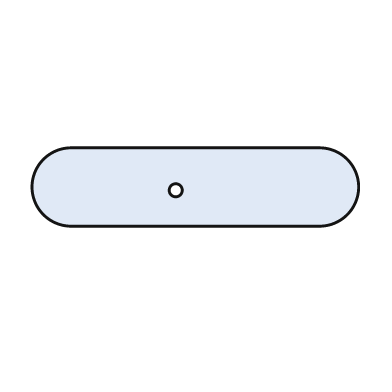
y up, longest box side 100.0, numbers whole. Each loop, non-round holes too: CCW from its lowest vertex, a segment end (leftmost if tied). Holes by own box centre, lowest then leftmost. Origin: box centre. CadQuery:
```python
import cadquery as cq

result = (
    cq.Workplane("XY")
    .moveTo(-38.0, -12.0)
    .lineTo(38.0, -12.0)
    .threePointArc((50.0, 0.0), (38.0, 12.0))
    .lineTo(-38.0, 12.0)
    .threePointArc((-50.0, 0.0), (-38.0, -12.0))
    .close()
    .moveTo(-6.0, -1.0)
    .circle(2.0)
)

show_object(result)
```